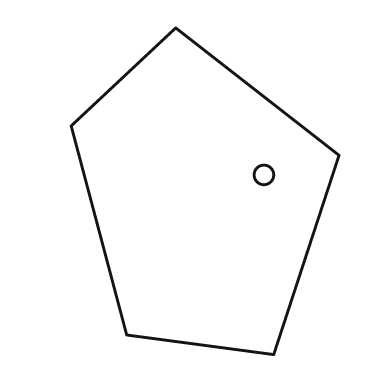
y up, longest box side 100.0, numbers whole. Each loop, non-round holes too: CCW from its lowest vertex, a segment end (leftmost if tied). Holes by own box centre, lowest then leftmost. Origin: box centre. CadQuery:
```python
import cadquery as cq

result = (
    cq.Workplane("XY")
    .moveTo(21.0, -50.0)
    .lineTo(41.0, 11.0)
    .lineTo(-9.0, 50.0)
    .lineTo(-41.0, 20.0)
    .lineTo(-24.0, -44.0)
    .close()
    .moveTo(18.0, 5.0)
    .circle(3.0)
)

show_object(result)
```